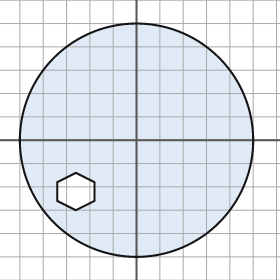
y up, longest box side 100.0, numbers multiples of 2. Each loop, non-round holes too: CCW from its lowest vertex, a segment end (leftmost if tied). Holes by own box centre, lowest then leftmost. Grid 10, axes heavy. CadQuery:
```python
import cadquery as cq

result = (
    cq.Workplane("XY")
    .moveTo(0.0, 0.0)
    .circle(50.0)
    .moveTo(-26.0, -30.0)
    .lineTo(-18.0, -26.0)
    .lineTo(-18.0, -18.0)
    .lineTo(-26.0, -14.0)
    .lineTo(-34.0, -18.0)
    .lineTo(-34.0, -26.0)
    .close()
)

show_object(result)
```